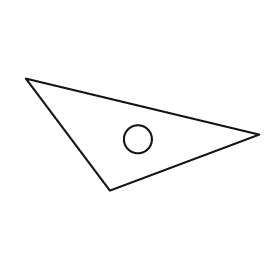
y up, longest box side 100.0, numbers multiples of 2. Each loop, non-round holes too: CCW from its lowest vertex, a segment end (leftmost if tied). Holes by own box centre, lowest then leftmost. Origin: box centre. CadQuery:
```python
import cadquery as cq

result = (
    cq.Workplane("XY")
    .moveTo(-14.0, -24.0)
    .lineTo(50.0, 0.0)
    .lineTo(-50.0, 24.0)
    .close()
    .moveTo(-2.0, -2.0)
    .circle(6.0)
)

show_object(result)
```